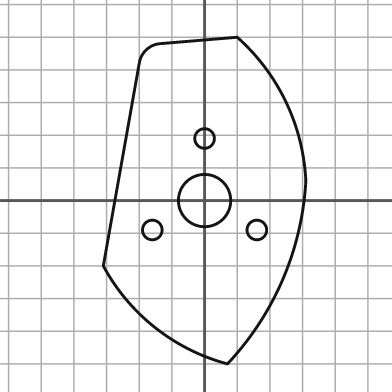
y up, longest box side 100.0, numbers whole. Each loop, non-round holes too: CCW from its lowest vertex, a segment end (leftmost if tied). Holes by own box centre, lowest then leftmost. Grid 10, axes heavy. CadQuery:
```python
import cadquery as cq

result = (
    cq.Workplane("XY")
    .moveTo(7.0, -50.0)
    .threePointArc((24.0, -24.0), (31.0, 6.0))
    .threePointArc((25.0, 30.0), (10.0, 50.0))
    .lineTo(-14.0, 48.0)
    .threePointArc((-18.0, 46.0), (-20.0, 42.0))
    .lineTo(-31.0, -20.0)
    .threePointArc((-15.0, -39.0), (7.0, -50.0))
    .close()
    .moveTo(-16.0, -9.0)
    .circle(3.0)
    .moveTo(16.0, -9.0)
    .circle(3.0)
    .moveTo(0.0, 0.0)
    .circle(8.0)
    .moveTo(0.0, 19.0)
    .circle(3.0)
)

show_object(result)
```